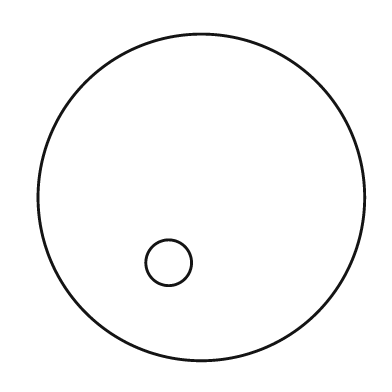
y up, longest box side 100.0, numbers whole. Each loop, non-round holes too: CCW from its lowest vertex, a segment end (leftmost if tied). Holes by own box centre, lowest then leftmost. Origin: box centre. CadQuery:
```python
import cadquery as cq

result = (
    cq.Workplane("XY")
    .moveTo(0.0, 0.0)
    .circle(50.0)
    .moveTo(-10.0, -20.0)
    .circle(7.0)
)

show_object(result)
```